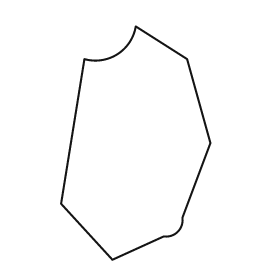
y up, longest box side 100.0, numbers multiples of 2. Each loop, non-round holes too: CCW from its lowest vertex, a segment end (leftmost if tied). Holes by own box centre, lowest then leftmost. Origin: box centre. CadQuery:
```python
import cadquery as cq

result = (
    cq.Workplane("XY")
    .moveTo(-10.0, -50.0)
    .lineTo(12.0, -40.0)
    .threePointArc((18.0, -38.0), (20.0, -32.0))
    .lineTo(32.0, 0.0)
    .lineTo(22.0, 36.0)
    .lineTo(0.0, 50.0)
    .threePointArc((-8.0, 38.0), (-22.0, 36.0))
    .lineTo(-32.0, -26.0)
    .close()
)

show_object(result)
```